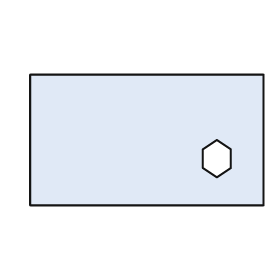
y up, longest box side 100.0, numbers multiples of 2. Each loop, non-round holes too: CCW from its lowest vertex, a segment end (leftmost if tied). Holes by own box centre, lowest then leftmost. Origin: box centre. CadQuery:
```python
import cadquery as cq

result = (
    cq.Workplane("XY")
    .moveTo(-50.0, -28.0)
    .lineTo(50.0, -28.0)
    .lineTo(50.0, 28.0)
    .lineTo(-50.0, 28.0)
    .close()
    .moveTo(30.0, -16.0)
    .lineTo(36.0, -12.0)
    .lineTo(36.0, -4.0)
    .lineTo(30.0, 0.0)
    .lineTo(24.0, -4.0)
    .lineTo(24.0, -12.0)
    .close()
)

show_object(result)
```